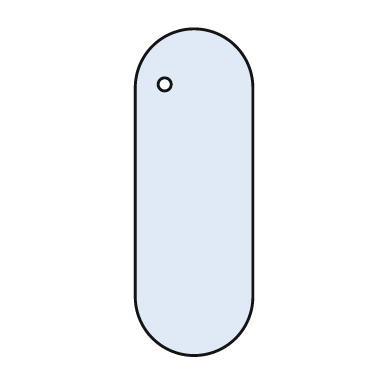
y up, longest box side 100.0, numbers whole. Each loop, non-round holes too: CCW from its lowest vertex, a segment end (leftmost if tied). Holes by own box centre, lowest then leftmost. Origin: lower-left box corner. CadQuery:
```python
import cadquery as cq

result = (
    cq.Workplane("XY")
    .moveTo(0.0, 18.0)
    .threePointArc((18.0, 0.0), (36.0, 18.0))
    .lineTo(36.0, 82.0)
    .threePointArc((18.0, 100.0), (0.0, 82.0))
    .close()
    .moveTo(9.0, 83.0)
    .circle(2.0)
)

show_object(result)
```